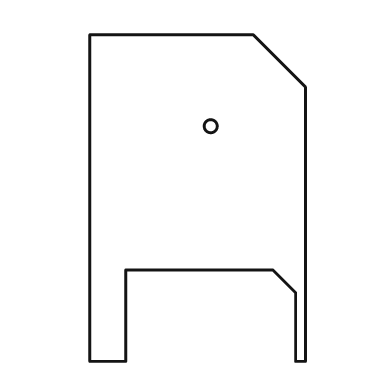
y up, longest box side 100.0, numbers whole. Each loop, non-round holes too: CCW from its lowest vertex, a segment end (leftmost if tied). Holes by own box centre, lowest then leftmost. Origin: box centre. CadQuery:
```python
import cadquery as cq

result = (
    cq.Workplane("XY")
    .moveTo(-33.0, -50.0)
    .lineTo(-22.0, -50.0)
    .lineTo(-22.0, -22.0)
    .lineTo(23.0, -22.0)
    .lineTo(30.0, -29.0)
    .lineTo(30.0, -50.0)
    .lineTo(33.0, -50.0)
    .lineTo(33.0, 34.0)
    .lineTo(17.0, 50.0)
    .lineTo(-33.0, 50.0)
    .close()
    .moveTo(4.0, 22.0)
    .circle(2.0)
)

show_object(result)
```